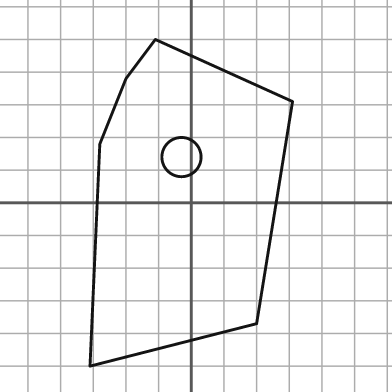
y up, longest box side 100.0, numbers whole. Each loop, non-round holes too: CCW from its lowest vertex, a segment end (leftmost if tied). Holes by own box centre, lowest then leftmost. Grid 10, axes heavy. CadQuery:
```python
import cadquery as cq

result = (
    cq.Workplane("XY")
    .moveTo(-31.0, -50.0)
    .lineTo(20.0, -37.0)
    .lineTo(31.0, 31.0)
    .lineTo(-11.0, 50.0)
    .lineTo(-20.0, 38.0)
    .lineTo(-28.0, 18.0)
    .close()
    .moveTo(-3.0, 14.0)
    .circle(6.0)
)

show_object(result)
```